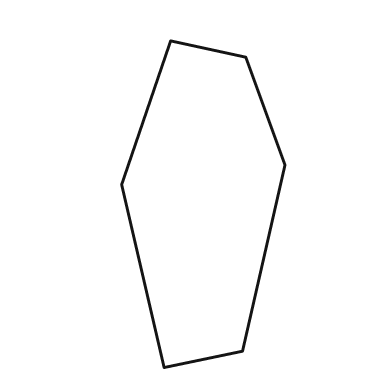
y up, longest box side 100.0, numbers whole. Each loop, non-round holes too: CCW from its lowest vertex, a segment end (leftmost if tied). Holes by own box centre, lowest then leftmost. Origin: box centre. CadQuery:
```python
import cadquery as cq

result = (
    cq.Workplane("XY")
    .moveTo(-12.0, -50.0)
    .lineTo(12.0, -45.0)
    .lineTo(25.0, 12.0)
    .lineTo(13.0, 45.0)
    .lineTo(-10.0, 50.0)
    .lineTo(-25.0, 6.0)
    .close()
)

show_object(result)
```